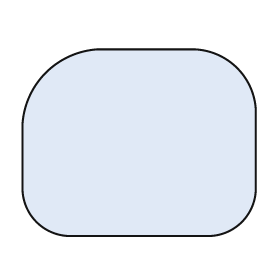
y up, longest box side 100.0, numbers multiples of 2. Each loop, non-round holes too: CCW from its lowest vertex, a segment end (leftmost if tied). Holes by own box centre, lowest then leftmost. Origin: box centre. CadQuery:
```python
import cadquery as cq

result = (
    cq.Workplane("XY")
    .moveTo(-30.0, -40.0)
    .lineTo(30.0, -40.0)
    .threePointArc((44.0, -34.0), (50.0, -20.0))
    .lineTo(50.0, 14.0)
    .threePointArc((42.0, 32.0), (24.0, 40.0))
    .lineTo(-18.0, 40.0)
    .threePointArc((-40.0, 30.0), (-50.0, 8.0))
    .lineTo(-50.0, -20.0)
    .threePointArc((-44.0, -34.0), (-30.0, -40.0))
    .close()
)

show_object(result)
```